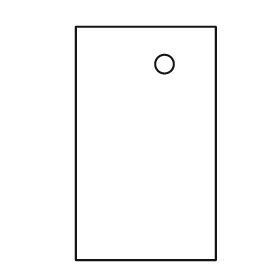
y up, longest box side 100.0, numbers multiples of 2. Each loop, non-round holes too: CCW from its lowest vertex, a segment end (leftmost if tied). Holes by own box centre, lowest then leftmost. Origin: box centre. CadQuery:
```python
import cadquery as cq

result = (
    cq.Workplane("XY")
    .moveTo(-30.0, -50.0)
    .lineTo(30.0, -50.0)
    .lineTo(30.0, 50.0)
    .lineTo(-30.0, 50.0)
    .close()
    .moveTo(8.0, 34.0)
    .circle(4.0)
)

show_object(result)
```